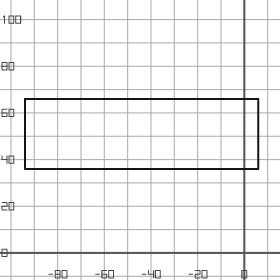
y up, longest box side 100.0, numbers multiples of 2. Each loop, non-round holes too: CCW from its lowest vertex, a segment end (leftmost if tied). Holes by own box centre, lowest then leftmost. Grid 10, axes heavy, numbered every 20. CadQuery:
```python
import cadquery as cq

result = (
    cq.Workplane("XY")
    .moveTo(-94.0, 36.0)
    .lineTo(6.0, 36.0)
    .lineTo(6.0, 66.0)
    .lineTo(-94.0, 66.0)
    .close()
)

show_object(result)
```